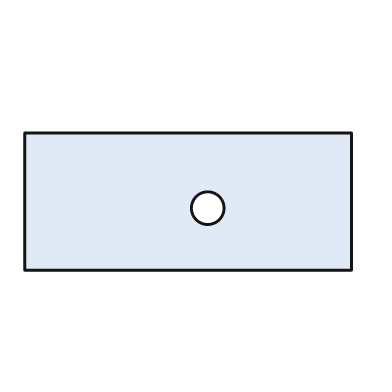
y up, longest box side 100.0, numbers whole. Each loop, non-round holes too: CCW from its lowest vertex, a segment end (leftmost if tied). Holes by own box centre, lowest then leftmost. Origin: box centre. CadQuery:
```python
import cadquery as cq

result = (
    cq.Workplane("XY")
    .moveTo(-50.0, -21.0)
    .lineTo(50.0, -21.0)
    .lineTo(50.0, 21.0)
    .lineTo(-50.0, 21.0)
    .close()
    .moveTo(6.0, -2.0)
    .circle(5.0)
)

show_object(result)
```